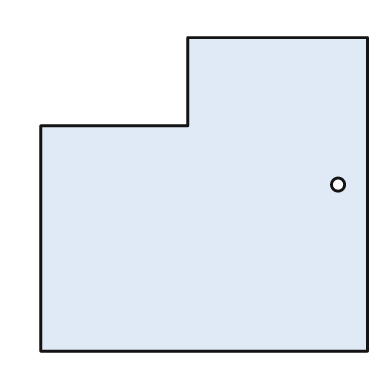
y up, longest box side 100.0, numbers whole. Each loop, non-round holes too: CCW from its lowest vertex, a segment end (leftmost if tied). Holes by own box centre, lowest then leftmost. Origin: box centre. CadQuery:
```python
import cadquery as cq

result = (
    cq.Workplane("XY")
    .moveTo(-50.0, -48.0)
    .lineTo(50.0, -48.0)
    .lineTo(50.0, 48.0)
    .lineTo(-5.0, 48.0)
    .lineTo(-5.0, 21.0)
    .lineTo(-50.0, 21.0)
    .close()
    .moveTo(41.0, 3.0)
    .circle(2.0)
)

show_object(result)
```